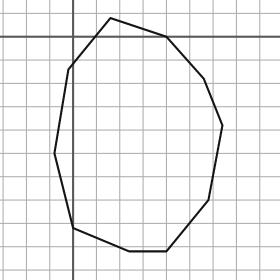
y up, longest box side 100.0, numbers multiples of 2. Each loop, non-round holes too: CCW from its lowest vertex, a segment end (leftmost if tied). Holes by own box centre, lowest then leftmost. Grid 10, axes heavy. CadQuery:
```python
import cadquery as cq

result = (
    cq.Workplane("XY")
    .moveTo(24.0, -92.0)
    .lineTo(40.0, -92.0)
    .lineTo(58.0, -70.0)
    .lineTo(64.0, -38.0)
    .lineTo(56.0, -18.0)
    .lineTo(40.0, 0.0)
    .lineTo(16.0, 8.0)
    .lineTo(-2.0, -14.0)
    .lineTo(-8.0, -50.0)
    .lineTo(0.0, -82.0)
    .close()
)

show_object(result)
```